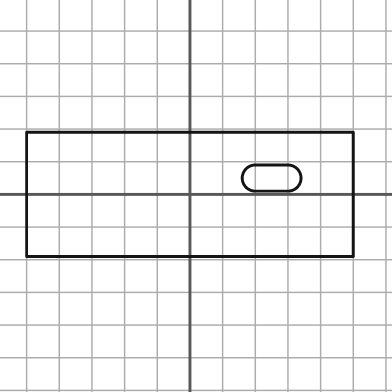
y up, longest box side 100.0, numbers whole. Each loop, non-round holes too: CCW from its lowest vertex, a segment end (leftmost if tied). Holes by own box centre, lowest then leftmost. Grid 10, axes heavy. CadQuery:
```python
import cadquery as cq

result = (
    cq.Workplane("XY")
    .moveTo(-50.0, -19.0)
    .lineTo(50.0, -19.0)
    .lineTo(50.0, 19.0)
    .lineTo(-50.0, 19.0)
    .close()
    .moveTo(20.0, 1.0)
    .lineTo(30.0, 1.0)
    .threePointArc((34.0, 5.0), (30.0, 9.0))
    .lineTo(20.0, 9.0)
    .threePointArc((16.0, 5.0), (20.0, 1.0))
    .close()
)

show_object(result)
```